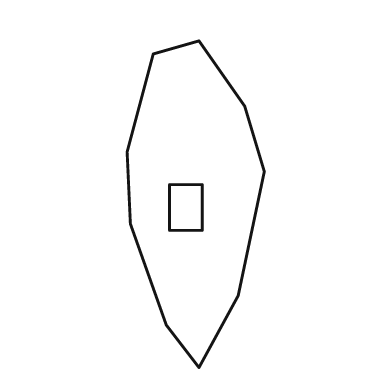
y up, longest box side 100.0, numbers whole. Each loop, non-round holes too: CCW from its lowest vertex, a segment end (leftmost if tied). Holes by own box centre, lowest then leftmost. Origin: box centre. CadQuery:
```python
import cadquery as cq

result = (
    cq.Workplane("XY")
    .moveTo(1.0, -50.0)
    .lineTo(13.0, -28.0)
    .lineTo(21.0, 10.0)
    .lineTo(15.0, 30.0)
    .lineTo(1.0, 50.0)
    .lineTo(-13.0, 46.0)
    .lineTo(-21.0, 16.0)
    .lineTo(-20.0, -6.0)
    .lineTo(-9.0, -37.0)
    .close()
    .moveTo(-8.0, -8.0)
    .lineTo(2.0, -8.0)
    .lineTo(2.0, 6.0)
    .lineTo(-8.0, 6.0)
    .close()
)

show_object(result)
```